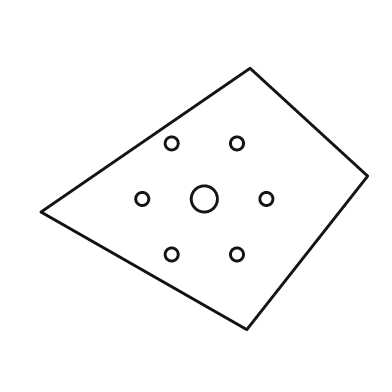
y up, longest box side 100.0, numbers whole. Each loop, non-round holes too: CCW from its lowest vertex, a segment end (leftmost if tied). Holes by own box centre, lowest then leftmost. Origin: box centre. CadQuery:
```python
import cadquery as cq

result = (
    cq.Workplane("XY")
    .moveTo(13.0, -40.0)
    .lineTo(50.0, 7.0)
    .lineTo(14.0, 40.0)
    .lineTo(-50.0, -4.0)
    .close()
    .moveTo(-10.0, -17.0)
    .circle(2.0)
    .moveTo(10.0, -17.0)
    .circle(2.0)
    .moveTo(-19.0, 0.0)
    .circle(2.0)
    .moveTo(0.0, 0.0)
    .circle(4.0)
    .moveTo(19.0, 0.0)
    .circle(2.0)
    .moveTo(-10.0, 17.0)
    .circle(2.0)
    .moveTo(10.0, 17.0)
    .circle(2.0)
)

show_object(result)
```